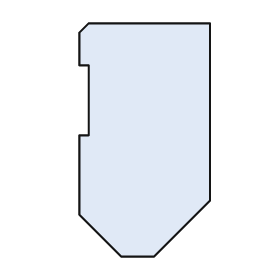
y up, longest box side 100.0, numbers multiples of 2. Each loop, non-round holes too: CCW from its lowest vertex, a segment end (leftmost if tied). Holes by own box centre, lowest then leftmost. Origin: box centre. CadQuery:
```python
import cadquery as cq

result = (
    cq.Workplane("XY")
    .moveTo(-10.0, -50.0)
    .lineTo(4.0, -50.0)
    .lineTo(28.0, -26.0)
    .lineTo(28.0, 50.0)
    .lineTo(-24.0, 50.0)
    .lineTo(-28.0, 46.0)
    .lineTo(-28.0, 32.0)
    .lineTo(-24.0, 32.0)
    .lineTo(-24.0, 2.0)
    .lineTo(-28.0, 2.0)
    .lineTo(-28.0, -32.0)
    .close()
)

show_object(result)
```